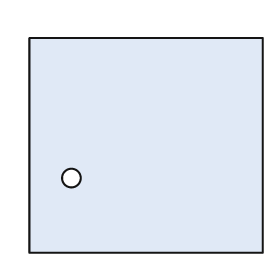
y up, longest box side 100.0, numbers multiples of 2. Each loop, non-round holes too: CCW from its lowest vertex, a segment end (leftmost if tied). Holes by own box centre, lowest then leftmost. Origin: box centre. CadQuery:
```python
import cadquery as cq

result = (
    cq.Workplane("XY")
    .moveTo(-50.0, -46.0)
    .lineTo(50.0, -46.0)
    .lineTo(50.0, 46.0)
    .lineTo(-50.0, 46.0)
    .close()
    .moveTo(-32.0, -14.0)
    .circle(4.0)
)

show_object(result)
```